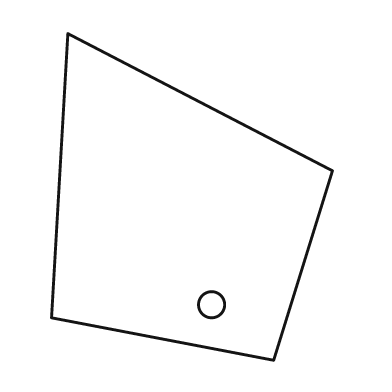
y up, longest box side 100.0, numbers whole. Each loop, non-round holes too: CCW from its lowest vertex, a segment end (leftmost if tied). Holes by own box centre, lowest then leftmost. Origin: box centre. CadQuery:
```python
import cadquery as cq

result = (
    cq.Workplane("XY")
    .moveTo(25.0, -50.0)
    .lineTo(43.0, 8.0)
    .lineTo(-38.0, 50.0)
    .lineTo(-43.0, -37.0)
    .close()
    .moveTo(6.0, -33.0)
    .circle(4.0)
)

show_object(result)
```